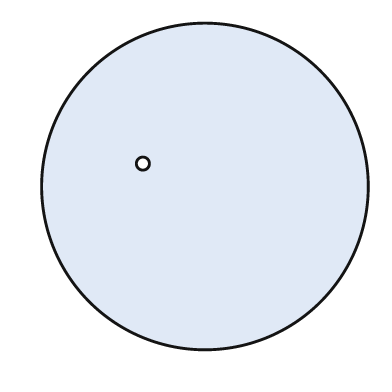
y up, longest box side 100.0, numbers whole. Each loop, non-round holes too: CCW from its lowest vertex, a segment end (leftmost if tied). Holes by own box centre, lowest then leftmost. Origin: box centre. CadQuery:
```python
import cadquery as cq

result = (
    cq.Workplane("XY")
    .moveTo(0.0, 0.0)
    .circle(50.0)
    .moveTo(-19.0, 7.0)
    .circle(2.0)
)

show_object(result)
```